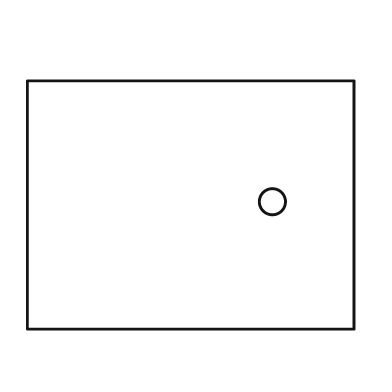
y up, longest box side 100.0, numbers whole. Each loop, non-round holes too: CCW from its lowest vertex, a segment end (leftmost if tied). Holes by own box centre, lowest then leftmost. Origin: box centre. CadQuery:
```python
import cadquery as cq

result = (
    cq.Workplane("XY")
    .moveTo(-50.0, -38.0)
    .lineTo(50.0, -38.0)
    .lineTo(50.0, 38.0)
    .lineTo(-50.0, 38.0)
    .close()
    .moveTo(25.0, 1.0)
    .circle(4.0)
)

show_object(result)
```